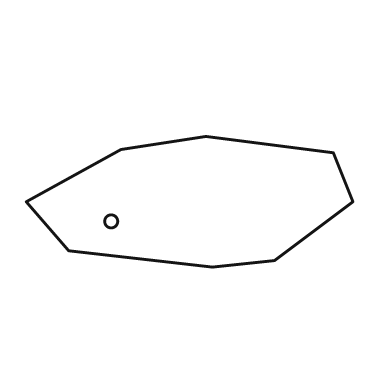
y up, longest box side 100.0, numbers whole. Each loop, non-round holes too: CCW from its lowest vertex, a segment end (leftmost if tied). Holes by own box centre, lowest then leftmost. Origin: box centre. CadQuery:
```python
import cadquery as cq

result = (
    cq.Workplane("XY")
    .moveTo(7.0, -20.0)
    .lineTo(26.0, -18.0)
    .lineTo(50.0, 0.0)
    .lineTo(44.0, 15.0)
    .lineTo(5.0, 20.0)
    .lineTo(-21.0, 16.0)
    .lineTo(-50.0, 0.0)
    .lineTo(-37.0, -15.0)
    .close()
    .moveTo(-24.0, -6.0)
    .circle(2.0)
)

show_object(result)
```